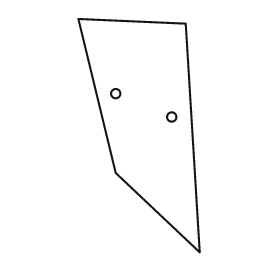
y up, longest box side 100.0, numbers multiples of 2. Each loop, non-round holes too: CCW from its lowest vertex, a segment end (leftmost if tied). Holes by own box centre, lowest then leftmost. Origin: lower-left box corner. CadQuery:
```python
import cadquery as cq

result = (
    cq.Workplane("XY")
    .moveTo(52.0, 0.0)
    .lineTo(46.0, 98.0)
    .lineTo(0.0, 100.0)
    .lineTo(16.0, 34.0)
    .close()
    .moveTo(40.0, 58.0)
    .circle(2.0)
    .moveTo(16.0, 68.0)
    .circle(2.0)
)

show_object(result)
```